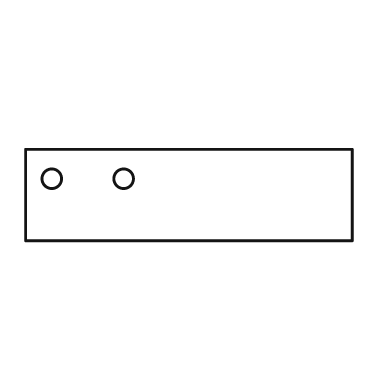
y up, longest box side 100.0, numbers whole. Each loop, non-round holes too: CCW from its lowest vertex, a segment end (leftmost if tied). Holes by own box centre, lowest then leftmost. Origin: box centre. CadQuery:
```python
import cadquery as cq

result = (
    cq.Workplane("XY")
    .moveTo(-50.0, -14.0)
    .lineTo(50.0, -14.0)
    .lineTo(50.0, 14.0)
    .lineTo(-50.0, 14.0)
    .close()
    .moveTo(-42.0, 5.0)
    .circle(3.0)
    .moveTo(-20.0, 5.0)
    .circle(3.0)
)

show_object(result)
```